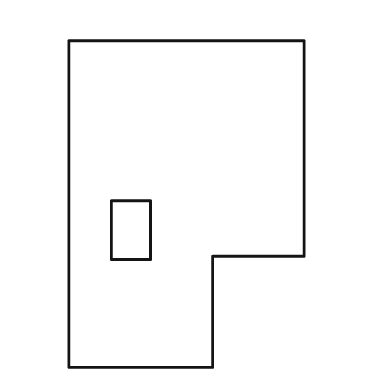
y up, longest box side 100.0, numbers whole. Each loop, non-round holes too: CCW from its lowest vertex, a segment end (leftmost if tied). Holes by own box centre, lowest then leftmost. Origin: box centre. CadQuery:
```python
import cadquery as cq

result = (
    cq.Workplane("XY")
    .moveTo(-36.0, -50.0)
    .lineTo(8.0, -50.0)
    .lineTo(8.0, -16.0)
    .lineTo(36.0, -16.0)
    .lineTo(36.0, 50.0)
    .lineTo(-36.0, 50.0)
    .close()
    .moveTo(-23.0, -17.0)
    .lineTo(-11.0, -17.0)
    .lineTo(-11.0, 1.0)
    .lineTo(-23.0, 1.0)
    .close()
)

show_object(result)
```